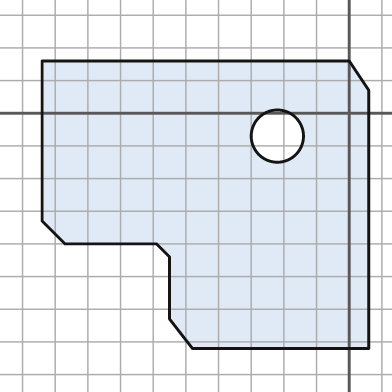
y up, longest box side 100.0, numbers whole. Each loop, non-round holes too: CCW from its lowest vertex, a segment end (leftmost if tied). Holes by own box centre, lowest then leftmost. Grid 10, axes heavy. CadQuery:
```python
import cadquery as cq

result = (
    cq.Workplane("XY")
    .moveTo(-48.0, -72.0)
    .lineTo(6.0, -72.0)
    .lineTo(6.0, 7.0)
    .lineTo(0.0, 16.0)
    .lineTo(-94.0, 16.0)
    .lineTo(-94.0, -33.0)
    .lineTo(-87.0, -40.0)
    .lineTo(-59.0, -40.0)
    .lineTo(-55.0, -44.0)
    .lineTo(-55.0, -63.0)
    .close()
    .moveTo(-22.0, -7.0)
    .circle(8.0)
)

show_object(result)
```